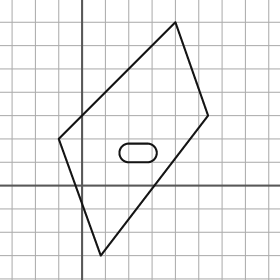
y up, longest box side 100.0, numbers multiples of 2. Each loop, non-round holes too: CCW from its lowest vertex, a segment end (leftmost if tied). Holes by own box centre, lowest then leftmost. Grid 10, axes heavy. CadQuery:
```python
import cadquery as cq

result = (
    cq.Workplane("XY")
    .moveTo(8.0, -30.0)
    .lineTo(54.0, 30.0)
    .lineTo(40.0, 70.0)
    .lineTo(-10.0, 20.0)
    .close()
    .moveTo(20.0, 10.0)
    .lineTo(28.0, 10.0)
    .threePointArc((32.0, 14.0), (28.0, 18.0))
    .lineTo(20.0, 18.0)
    .threePointArc((16.0, 14.0), (20.0, 10.0))
    .close()
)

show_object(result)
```